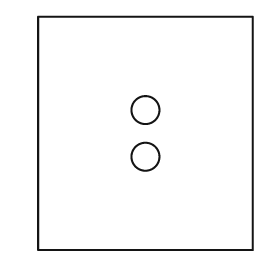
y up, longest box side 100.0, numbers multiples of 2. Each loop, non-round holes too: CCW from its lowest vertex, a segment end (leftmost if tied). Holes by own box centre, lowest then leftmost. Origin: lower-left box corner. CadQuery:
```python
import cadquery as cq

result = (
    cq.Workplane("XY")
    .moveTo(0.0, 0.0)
    .lineTo(92.0, 0.0)
    .lineTo(92.0, 100.0)
    .lineTo(0.0, 100.0)
    .close()
    .moveTo(46.0, 40.0)
    .circle(6.0)
    .moveTo(46.0, 60.0)
    .circle(6.0)
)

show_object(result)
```